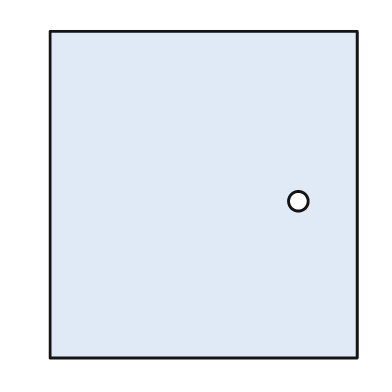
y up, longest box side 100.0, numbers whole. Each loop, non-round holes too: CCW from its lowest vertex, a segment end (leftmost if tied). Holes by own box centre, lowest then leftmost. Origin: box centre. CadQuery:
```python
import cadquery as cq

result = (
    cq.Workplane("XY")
    .moveTo(-47.0, -50.0)
    .lineTo(47.0, -50.0)
    .lineTo(47.0, 50.0)
    .lineTo(-47.0, 50.0)
    .close()
    .moveTo(29.0, -2.0)
    .circle(3.0)
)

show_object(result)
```